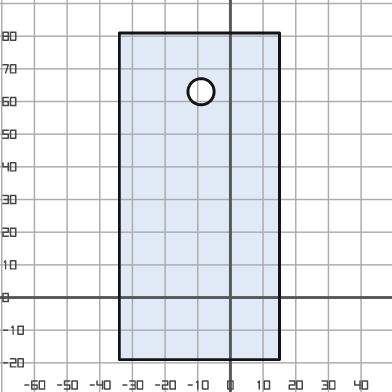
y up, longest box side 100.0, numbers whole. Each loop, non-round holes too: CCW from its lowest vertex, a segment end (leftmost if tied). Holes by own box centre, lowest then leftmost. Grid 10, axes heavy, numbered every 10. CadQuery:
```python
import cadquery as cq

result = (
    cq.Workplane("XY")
    .moveTo(-34.0, -19.0)
    .lineTo(15.0, -19.0)
    .lineTo(15.0, 81.0)
    .lineTo(-34.0, 81.0)
    .close()
    .moveTo(-9.0, 63.0)
    .circle(4.0)
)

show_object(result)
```